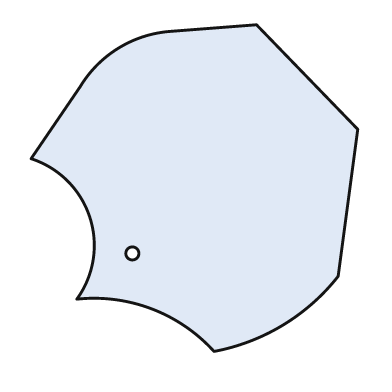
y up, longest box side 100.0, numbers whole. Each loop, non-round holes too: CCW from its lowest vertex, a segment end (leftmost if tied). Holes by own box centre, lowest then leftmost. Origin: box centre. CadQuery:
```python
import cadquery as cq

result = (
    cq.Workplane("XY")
    .moveTo(6.0, -50.0)
    .threePointArc((27.0, -42.0), (44.0, -27.0))
    .lineTo(50.0, 18.0)
    .lineTo(19.0, 50.0)
    .lineTo(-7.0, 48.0)
    .threePointArc((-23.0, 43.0), (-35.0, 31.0))
    .lineTo(-50.0, 9.0)
    .threePointArc((-32.0, -9.0), (-36.0, -34.0))
    .threePointArc((-13.0, -37.0), (6.0, -50.0))
    .close()
    .moveTo(-19.0, -20.0)
    .circle(2.0)
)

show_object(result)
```